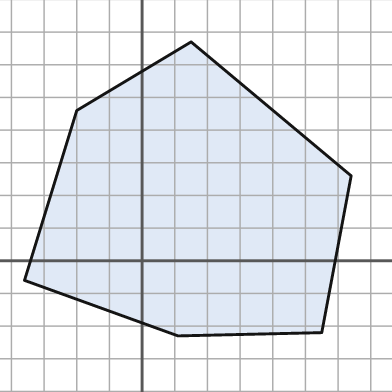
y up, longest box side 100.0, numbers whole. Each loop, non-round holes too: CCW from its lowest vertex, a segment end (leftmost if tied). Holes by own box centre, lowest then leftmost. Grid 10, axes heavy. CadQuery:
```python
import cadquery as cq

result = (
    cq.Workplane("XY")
    .moveTo(11.0, -23.0)
    .lineTo(55.0, -22.0)
    .lineTo(64.0, 26.0)
    .lineTo(15.0, 67.0)
    .lineTo(-20.0, 46.0)
    .lineTo(-36.0, -6.0)
    .close()
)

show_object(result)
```